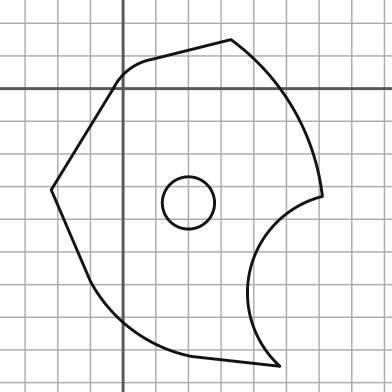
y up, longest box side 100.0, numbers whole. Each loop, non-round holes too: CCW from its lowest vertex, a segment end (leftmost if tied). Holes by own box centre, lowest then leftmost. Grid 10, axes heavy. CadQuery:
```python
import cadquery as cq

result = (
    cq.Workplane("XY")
    .moveTo(48.0, -85.0)
    .threePointArc((39.0, -55.0), (61.0, -33.0))
    .threePointArc((52.0, -6.0), (33.0, 15.0))
    .lineTo(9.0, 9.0)
    .threePointArc((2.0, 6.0), (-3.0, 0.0))
    .lineTo(-22.0, -31.0)
    .lineTo(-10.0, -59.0)
    .threePointArc((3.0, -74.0), (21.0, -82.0))
    .close()
    .moveTo(20.0, -35.0)
    .circle(8.0)
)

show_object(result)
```